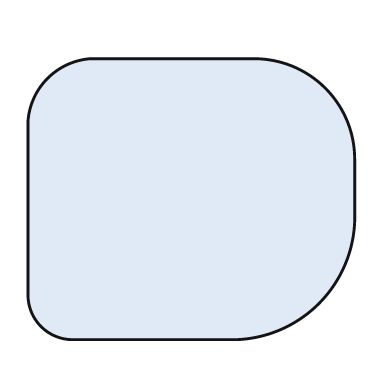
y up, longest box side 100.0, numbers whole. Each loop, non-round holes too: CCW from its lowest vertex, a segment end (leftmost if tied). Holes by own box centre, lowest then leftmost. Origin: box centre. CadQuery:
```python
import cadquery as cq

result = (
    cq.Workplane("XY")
    .moveTo(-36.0, -43.0)
    .lineTo(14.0, -43.0)
    .threePointArc((39.0, -32.0), (50.0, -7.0))
    .lineTo(50.0, 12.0)
    .threePointArc((41.0, 34.0), (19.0, 43.0))
    .lineTo(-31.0, 43.0)
    .threePointArc((-44.0, 37.0), (-50.0, 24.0))
    .lineTo(-50.0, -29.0)
    .threePointArc((-46.0, -39.0), (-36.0, -43.0))
    .close()
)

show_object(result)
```